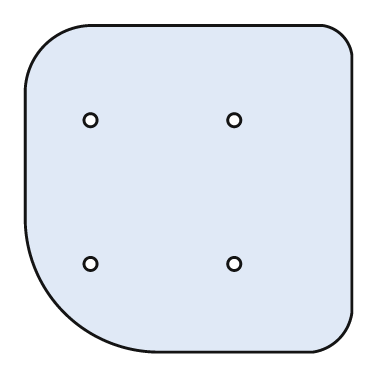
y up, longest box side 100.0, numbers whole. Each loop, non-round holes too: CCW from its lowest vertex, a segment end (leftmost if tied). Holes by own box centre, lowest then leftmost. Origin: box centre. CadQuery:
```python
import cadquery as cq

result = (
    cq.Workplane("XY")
    .moveTo(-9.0, -50.0)
    .lineTo(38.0, -50.0)
    .threePointArc((46.0, -46.0), (50.0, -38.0))
    .lineTo(50.0, 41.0)
    .threePointArc((47.0, 47.0), (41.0, 50.0))
    .lineTo(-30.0, 50.0)
    .threePointArc((-44.0, 44.0), (-50.0, 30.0))
    .lineTo(-50.0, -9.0)
    .threePointArc((-38.0, -38.0), (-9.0, -50.0))
    .close()
    .moveTo(-30.0, -23.0)
    .circle(2.0)
    .moveTo(14.0, -23.0)
    .circle(2.0)
    .moveTo(-30.0, 21.0)
    .circle(2.0)
    .moveTo(14.0, 21.0)
    .circle(2.0)
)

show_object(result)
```